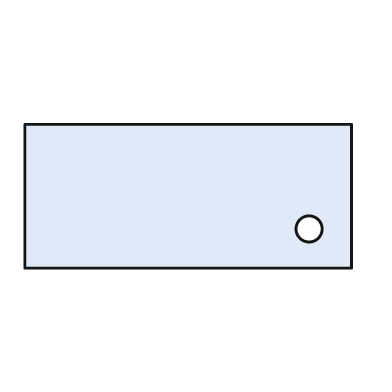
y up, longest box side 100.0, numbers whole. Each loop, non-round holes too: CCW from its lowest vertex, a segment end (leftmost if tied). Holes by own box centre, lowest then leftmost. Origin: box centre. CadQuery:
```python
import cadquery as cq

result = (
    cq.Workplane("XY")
    .moveTo(-50.0, -22.0)
    .lineTo(50.0, -22.0)
    .lineTo(50.0, 22.0)
    .lineTo(-50.0, 22.0)
    .close()
    .moveTo(37.0, -10.0)
    .circle(4.0)
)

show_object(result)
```